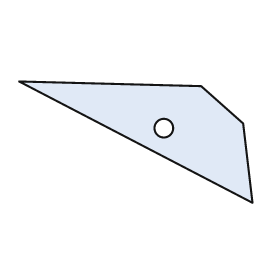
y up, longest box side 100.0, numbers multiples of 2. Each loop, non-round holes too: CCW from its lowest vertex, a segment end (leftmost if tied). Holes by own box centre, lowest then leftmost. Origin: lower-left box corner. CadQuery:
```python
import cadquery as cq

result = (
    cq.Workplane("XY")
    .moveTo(100.0, 0.0)
    .lineTo(96.0, 34.0)
    .lineTo(78.0, 50.0)
    .lineTo(0.0, 52.0)
    .close()
    .moveTo(62.0, 32.0)
    .circle(4.0)
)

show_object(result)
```